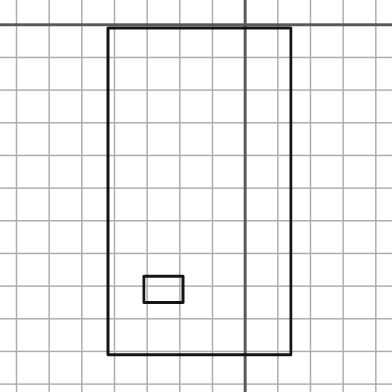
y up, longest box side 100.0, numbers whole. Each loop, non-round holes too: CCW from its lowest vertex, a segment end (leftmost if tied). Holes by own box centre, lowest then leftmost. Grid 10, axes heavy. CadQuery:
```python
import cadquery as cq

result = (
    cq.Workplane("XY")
    .moveTo(-42.0, -101.0)
    .lineTo(14.0, -101.0)
    .lineTo(14.0, -1.0)
    .lineTo(-42.0, -1.0)
    .close()
    .moveTo(-31.0, -85.0)
    .lineTo(-19.0, -85.0)
    .lineTo(-19.0, -77.0)
    .lineTo(-31.0, -77.0)
    .close()
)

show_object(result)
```